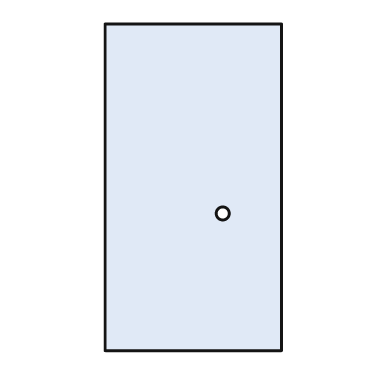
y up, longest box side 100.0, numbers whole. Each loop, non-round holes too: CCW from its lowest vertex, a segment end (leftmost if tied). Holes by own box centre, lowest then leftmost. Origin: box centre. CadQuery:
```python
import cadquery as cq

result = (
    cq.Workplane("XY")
    .moveTo(-27.0, -50.0)
    .lineTo(27.0, -50.0)
    .lineTo(27.0, 50.0)
    .lineTo(-27.0, 50.0)
    .close()
    .moveTo(9.0, -8.0)
    .circle(2.0)
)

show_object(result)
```